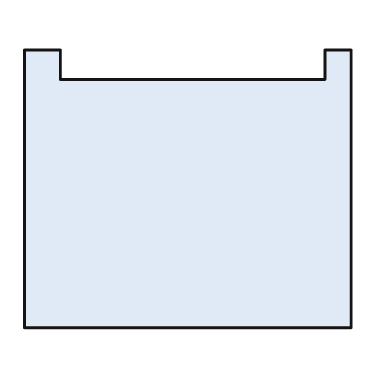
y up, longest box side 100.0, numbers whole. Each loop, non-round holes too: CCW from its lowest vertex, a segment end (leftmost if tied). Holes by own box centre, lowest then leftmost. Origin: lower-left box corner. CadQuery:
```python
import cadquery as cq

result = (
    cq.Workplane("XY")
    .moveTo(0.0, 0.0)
    .lineTo(100.0, 0.0)
    .lineTo(100.0, 85.0)
    .lineTo(92.0, 85.0)
    .lineTo(92.0, 76.0)
    .lineTo(11.0, 76.0)
    .lineTo(11.0, 85.0)
    .lineTo(0.0, 85.0)
    .close()
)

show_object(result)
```